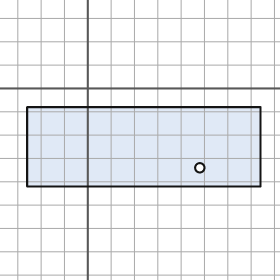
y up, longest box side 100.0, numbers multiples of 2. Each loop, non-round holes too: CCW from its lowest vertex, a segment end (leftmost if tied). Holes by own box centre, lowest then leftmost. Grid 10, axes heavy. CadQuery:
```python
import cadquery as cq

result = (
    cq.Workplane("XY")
    .moveTo(-26.0, -42.0)
    .lineTo(74.0, -42.0)
    .lineTo(74.0, -8.0)
    .lineTo(-26.0, -8.0)
    .close()
    .moveTo(48.0, -34.0)
    .circle(2.0)
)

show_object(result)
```